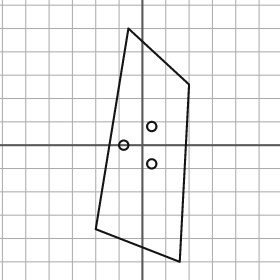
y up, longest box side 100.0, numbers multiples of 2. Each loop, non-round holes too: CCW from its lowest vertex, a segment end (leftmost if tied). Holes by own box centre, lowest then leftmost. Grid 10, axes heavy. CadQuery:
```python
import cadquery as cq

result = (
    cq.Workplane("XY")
    .moveTo(16.0, -50.0)
    .lineTo(20.0, 26.0)
    .lineTo(-6.0, 50.0)
    .lineTo(-20.0, -36.0)
    .close()
    .moveTo(4.0, -8.0)
    .circle(2.0)
    .moveTo(-8.0, 0.0)
    .circle(2.0)
    .moveTo(4.0, 8.0)
    .circle(2.0)
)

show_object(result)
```